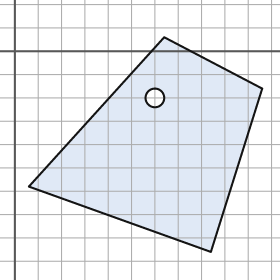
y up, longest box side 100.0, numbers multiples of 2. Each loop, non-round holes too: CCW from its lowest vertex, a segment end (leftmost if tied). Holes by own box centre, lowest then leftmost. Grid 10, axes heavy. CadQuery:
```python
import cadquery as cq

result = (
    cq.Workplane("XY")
    .moveTo(84.0, -86.0)
    .lineTo(106.0, -16.0)
    .lineTo(64.0, 6.0)
    .lineTo(6.0, -58.0)
    .close()
    .moveTo(60.0, -20.0)
    .circle(4.0)
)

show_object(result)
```